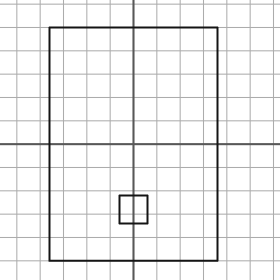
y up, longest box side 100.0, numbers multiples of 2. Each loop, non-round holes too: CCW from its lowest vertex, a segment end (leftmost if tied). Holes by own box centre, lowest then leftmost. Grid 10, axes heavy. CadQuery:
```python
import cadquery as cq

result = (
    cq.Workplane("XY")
    .moveTo(-36.0, -50.0)
    .lineTo(36.0, -50.0)
    .lineTo(36.0, 50.0)
    .lineTo(-36.0, 50.0)
    .close()
    .moveTo(-6.0, -34.0)
    .lineTo(6.0, -34.0)
    .lineTo(6.0, -22.0)
    .lineTo(-6.0, -22.0)
    .close()
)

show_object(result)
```